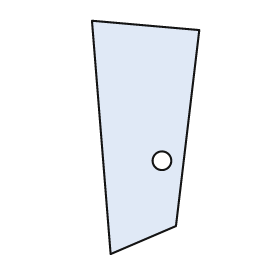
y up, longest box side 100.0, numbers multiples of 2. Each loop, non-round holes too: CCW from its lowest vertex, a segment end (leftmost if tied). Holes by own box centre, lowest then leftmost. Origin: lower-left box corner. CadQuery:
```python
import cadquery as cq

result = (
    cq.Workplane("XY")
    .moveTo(8.0, 0.0)
    .lineTo(36.0, 12.0)
    .lineTo(46.0, 96.0)
    .lineTo(0.0, 100.0)
    .close()
    .moveTo(30.0, 40.0)
    .circle(4.0)
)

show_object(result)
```